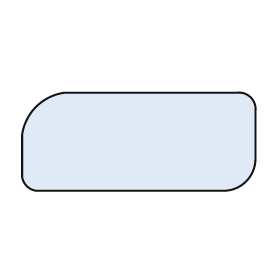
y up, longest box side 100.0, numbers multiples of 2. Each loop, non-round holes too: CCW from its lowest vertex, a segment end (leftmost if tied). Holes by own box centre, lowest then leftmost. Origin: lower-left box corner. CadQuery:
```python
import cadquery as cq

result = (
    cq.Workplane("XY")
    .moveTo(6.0, 0.0)
    .lineTo(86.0, 0.0)
    .threePointArc((96.0, 4.0), (100.0, 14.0))
    .lineTo(100.0, 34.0)
    .threePointArc((98.0, 40.0), (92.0, 42.0))
    .lineTo(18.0, 42.0)
    .threePointArc((6.0, 36.0), (0.0, 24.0))
    .lineTo(0.0, 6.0)
    .threePointArc((2.0, 2.0), (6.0, 0.0))
    .close()
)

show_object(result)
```